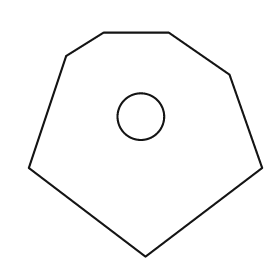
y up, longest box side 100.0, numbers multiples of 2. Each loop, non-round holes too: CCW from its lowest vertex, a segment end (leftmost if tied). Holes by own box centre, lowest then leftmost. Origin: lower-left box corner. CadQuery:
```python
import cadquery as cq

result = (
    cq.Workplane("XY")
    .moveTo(50.0, 0.0)
    .lineTo(100.0, 38.0)
    .lineTo(86.0, 78.0)
    .lineTo(60.0, 96.0)
    .lineTo(32.0, 96.0)
    .lineTo(16.0, 86.0)
    .lineTo(0.0, 38.0)
    .close()
    .moveTo(48.0, 60.0)
    .circle(10.0)
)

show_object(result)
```